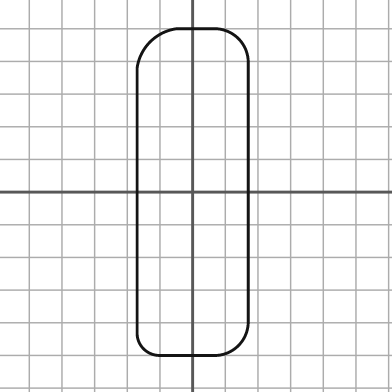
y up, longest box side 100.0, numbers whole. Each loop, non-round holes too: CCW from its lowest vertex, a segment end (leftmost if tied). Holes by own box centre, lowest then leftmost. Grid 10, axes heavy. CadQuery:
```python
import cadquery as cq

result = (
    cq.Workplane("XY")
    .moveTo(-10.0, -50.0)
    .lineTo(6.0, -50.0)
    .threePointArc((14.0, -47.0), (17.0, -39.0))
    .lineTo(17.0, 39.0)
    .threePointArc((14.0, 47.0), (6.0, 50.0))
    .lineTo(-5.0, 50.0)
    .threePointArc((-13.0, 46.0), (-17.0, 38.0))
    .lineTo(-17.0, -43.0)
    .threePointArc((-15.0, -48.0), (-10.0, -50.0))
    .close()
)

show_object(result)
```